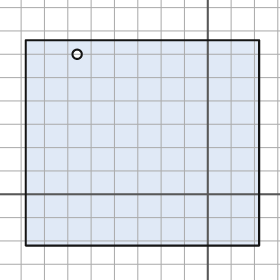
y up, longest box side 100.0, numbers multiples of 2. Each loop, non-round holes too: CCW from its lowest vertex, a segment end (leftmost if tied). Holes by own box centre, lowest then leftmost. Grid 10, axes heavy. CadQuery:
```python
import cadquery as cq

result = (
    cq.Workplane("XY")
    .moveTo(-78.0, -22.0)
    .lineTo(22.0, -22.0)
    .lineTo(22.0, 66.0)
    .lineTo(-78.0, 66.0)
    .close()
    .moveTo(-56.0, 60.0)
    .circle(2.0)
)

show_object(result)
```